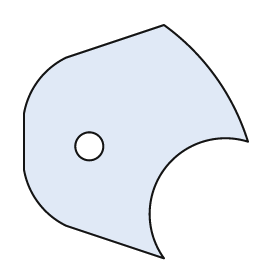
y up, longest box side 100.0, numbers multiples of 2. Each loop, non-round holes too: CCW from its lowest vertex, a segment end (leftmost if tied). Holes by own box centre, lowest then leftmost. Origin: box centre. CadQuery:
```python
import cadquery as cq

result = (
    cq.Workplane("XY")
    .moveTo(12.0, -50.0)
    .threePointArc((12.0, -12.0), (48.0, 0.0))
    .threePointArc((34.0, 28.0), (12.0, 50.0))
    .lineTo(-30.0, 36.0)
    .threePointArc((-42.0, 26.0), (-48.0, 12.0))
    .lineTo(-48.0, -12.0)
    .threePointArc((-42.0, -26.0), (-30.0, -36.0))
    .close()
    .moveTo(-20.0, -2.0)
    .circle(6.0)
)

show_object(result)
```